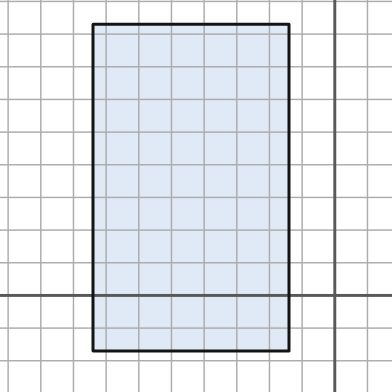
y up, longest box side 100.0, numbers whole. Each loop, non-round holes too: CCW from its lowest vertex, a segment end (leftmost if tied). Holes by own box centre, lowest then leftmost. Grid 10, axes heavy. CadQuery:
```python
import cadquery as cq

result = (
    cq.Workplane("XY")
    .moveTo(-74.0, -17.0)
    .lineTo(-14.0, -17.0)
    .lineTo(-14.0, 83.0)
    .lineTo(-74.0, 83.0)
    .close()
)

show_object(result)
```